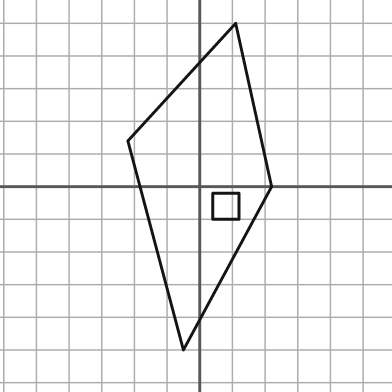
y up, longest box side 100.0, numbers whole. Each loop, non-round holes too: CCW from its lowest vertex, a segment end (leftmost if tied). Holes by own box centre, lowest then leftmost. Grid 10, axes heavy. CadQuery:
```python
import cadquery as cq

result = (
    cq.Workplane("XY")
    .moveTo(-5.0, -50.0)
    .lineTo(22.0, 0.0)
    .lineTo(11.0, 50.0)
    .lineTo(-22.0, 14.0)
    .close()
    .moveTo(4.0, -10.0)
    .lineTo(12.0, -10.0)
    .lineTo(12.0, -2.0)
    .lineTo(4.0, -2.0)
    .close()
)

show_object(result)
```